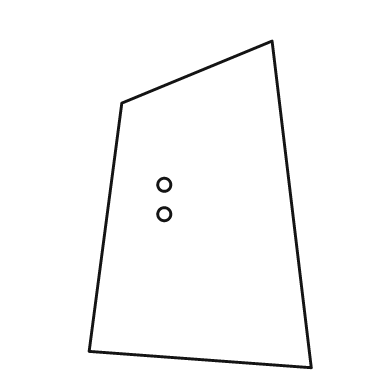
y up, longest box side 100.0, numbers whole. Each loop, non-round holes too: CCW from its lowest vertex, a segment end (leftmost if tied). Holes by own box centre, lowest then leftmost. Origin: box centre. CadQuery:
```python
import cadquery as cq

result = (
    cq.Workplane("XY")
    .moveTo(34.0, -50.0)
    .lineTo(22.0, 50.0)
    .lineTo(-24.0, 31.0)
    .lineTo(-34.0, -45.0)
    .close()
    .moveTo(-11.0, -3.0)
    .circle(2.0)
    .moveTo(-11.0, 6.0)
    .circle(2.0)
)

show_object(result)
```